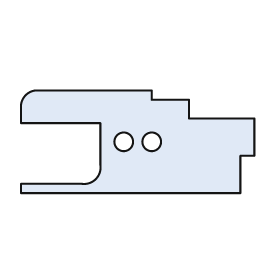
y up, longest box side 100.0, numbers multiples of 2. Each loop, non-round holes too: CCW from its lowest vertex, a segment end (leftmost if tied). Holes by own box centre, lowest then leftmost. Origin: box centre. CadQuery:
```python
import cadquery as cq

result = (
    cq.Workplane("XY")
    .moveTo(-50.0, -22.0)
    .lineTo(44.0, -22.0)
    .lineTo(44.0, -6.0)
    .lineTo(50.0, -6.0)
    .lineTo(50.0, 10.0)
    .lineTo(22.0, 10.0)
    .lineTo(22.0, 18.0)
    .lineTo(6.0, 18.0)
    .lineTo(6.0, 22.0)
    .lineTo(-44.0, 22.0)
    .threePointArc((-48.0, 20.0), (-50.0, 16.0))
    .lineTo(-50.0, 8.0)
    .lineTo(-16.0, 8.0)
    .lineTo(-16.0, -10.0)
    .threePointArc((-18.0, -16.0), (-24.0, -18.0))
    .lineTo(-50.0, -18.0)
    .close()
    .moveTo(-6.0, 0.0)
    .circle(4.0)
    .moveTo(6.0, 0.0)
    .circle(4.0)
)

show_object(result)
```